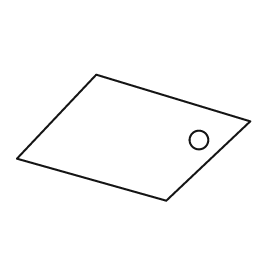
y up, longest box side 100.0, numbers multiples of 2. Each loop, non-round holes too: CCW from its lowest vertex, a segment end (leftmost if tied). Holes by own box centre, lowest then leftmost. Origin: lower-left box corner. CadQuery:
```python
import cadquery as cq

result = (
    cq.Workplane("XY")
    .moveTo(64.0, 0.0)
    .lineTo(100.0, 34.0)
    .lineTo(34.0, 54.0)
    .lineTo(0.0, 18.0)
    .close()
    .moveTo(78.0, 26.0)
    .circle(4.0)
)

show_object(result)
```